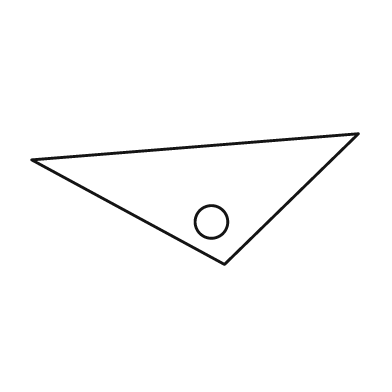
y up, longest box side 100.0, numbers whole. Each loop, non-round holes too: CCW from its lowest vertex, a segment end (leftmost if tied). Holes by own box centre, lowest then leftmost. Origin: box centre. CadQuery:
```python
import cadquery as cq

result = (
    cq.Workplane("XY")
    .moveTo(9.0, -20.0)
    .lineTo(50.0, 20.0)
    .lineTo(-50.0, 12.0)
    .close()
    .moveTo(5.0, -7.0)
    .circle(5.0)
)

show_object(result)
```